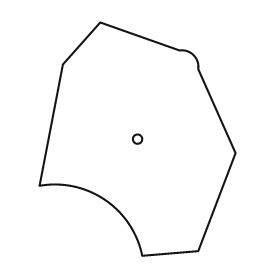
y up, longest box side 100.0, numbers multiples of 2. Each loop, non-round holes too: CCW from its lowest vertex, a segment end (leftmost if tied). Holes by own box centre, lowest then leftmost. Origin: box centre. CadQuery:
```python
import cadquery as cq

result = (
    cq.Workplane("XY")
    .moveTo(2.0, -50.0)
    .lineTo(26.0, -48.0)
    .lineTo(42.0, -6.0)
    .lineTo(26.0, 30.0)
    .threePointArc((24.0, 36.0), (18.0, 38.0))
    .lineTo(-16.0, 50.0)
    .lineTo(-32.0, 32.0)
    .lineTo(-42.0, -20.0)
    .threePointArc((-14.0, -26.0), (2.0, -50.0))
    .close()
    .moveTo(0.0, 0.0)
    .circle(2.0)
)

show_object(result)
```